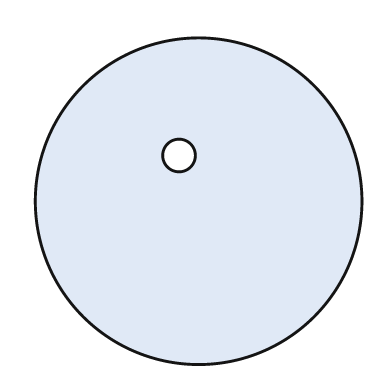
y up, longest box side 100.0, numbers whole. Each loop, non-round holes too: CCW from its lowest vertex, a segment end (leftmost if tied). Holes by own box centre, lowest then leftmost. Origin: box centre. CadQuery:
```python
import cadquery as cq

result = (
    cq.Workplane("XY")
    .moveTo(0.0, 0.0)
    .circle(50.0)
    .moveTo(-6.0, 14.0)
    .circle(5.0)
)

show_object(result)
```